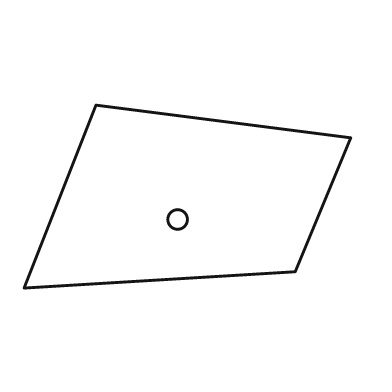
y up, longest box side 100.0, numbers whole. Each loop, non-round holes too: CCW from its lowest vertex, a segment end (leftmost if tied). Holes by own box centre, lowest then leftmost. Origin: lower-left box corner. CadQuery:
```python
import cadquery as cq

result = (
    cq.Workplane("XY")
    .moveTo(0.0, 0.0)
    .lineTo(83.0, 5.0)
    .lineTo(100.0, 46.0)
    .lineTo(22.0, 56.0)
    .close()
    .moveTo(47.0, 21.0)
    .circle(3.0)
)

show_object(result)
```